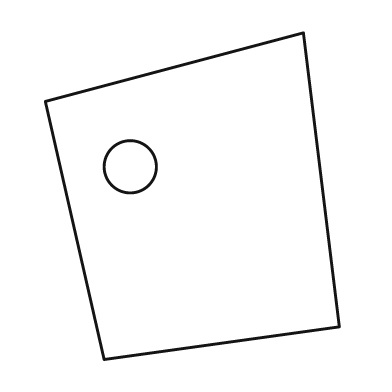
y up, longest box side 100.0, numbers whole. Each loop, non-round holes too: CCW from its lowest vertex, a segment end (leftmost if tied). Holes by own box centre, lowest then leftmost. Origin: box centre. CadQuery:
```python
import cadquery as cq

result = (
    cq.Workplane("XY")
    .moveTo(-27.0, -50.0)
    .lineTo(45.0, -40.0)
    .lineTo(34.0, 50.0)
    .lineTo(-45.0, 29.0)
    .close()
    .moveTo(-19.0, 9.0)
    .circle(8.0)
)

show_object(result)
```